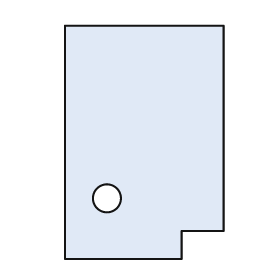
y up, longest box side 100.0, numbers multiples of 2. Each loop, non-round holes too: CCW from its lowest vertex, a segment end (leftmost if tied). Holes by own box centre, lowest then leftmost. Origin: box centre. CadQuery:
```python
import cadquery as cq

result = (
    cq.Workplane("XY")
    .moveTo(-34.0, -50.0)
    .lineTo(16.0, -50.0)
    .lineTo(16.0, -38.0)
    .lineTo(34.0, -38.0)
    .lineTo(34.0, 50.0)
    .lineTo(-34.0, 50.0)
    .close()
    .moveTo(-16.0, -24.0)
    .circle(6.0)
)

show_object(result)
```